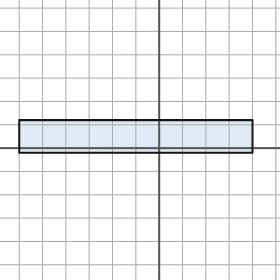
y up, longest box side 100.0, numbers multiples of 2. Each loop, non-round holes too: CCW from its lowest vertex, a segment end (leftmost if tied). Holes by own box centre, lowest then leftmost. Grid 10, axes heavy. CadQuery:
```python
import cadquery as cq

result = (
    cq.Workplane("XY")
    .moveTo(-60.0, -2.0)
    .lineTo(40.0, -2.0)
    .lineTo(40.0, 12.0)
    .lineTo(-60.0, 12.0)
    .close()
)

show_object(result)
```